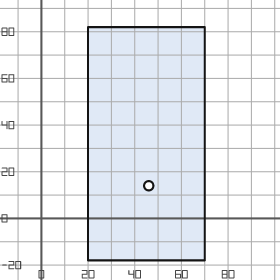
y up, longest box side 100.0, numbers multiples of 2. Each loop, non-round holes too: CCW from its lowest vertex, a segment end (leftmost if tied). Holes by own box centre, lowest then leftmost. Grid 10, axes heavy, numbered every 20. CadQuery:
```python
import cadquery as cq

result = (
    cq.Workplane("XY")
    .moveTo(20.0, -18.0)
    .lineTo(70.0, -18.0)
    .lineTo(70.0, 82.0)
    .lineTo(20.0, 82.0)
    .close()
    .moveTo(46.0, 14.0)
    .circle(2.0)
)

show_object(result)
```